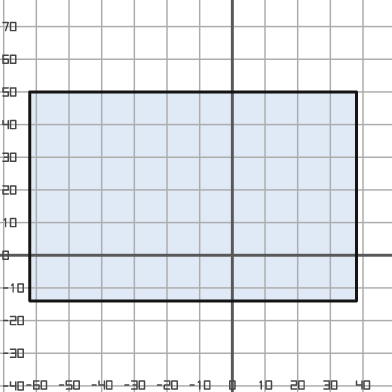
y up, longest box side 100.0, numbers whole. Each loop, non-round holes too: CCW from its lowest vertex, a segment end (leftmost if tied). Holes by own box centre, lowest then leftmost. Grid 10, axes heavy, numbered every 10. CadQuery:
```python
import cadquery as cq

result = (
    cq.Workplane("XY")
    .moveTo(-62.0, -14.0)
    .lineTo(38.0, -14.0)
    .lineTo(38.0, 50.0)
    .lineTo(-62.0, 50.0)
    .close()
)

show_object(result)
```